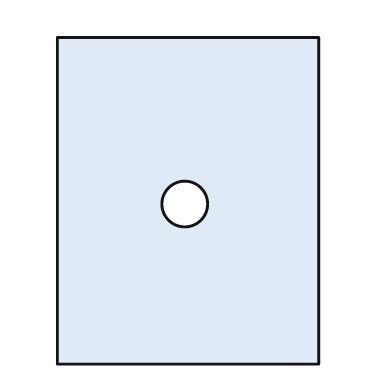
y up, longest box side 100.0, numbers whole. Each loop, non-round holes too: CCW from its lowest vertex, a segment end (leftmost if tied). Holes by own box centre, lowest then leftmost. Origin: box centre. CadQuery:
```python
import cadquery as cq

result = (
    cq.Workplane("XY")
    .moveTo(-40.0, -50.0)
    .lineTo(40.0, -50.0)
    .lineTo(40.0, 50.0)
    .lineTo(-40.0, 50.0)
    .close()
    .moveTo(-1.0, -1.0)
    .circle(7.0)
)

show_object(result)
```